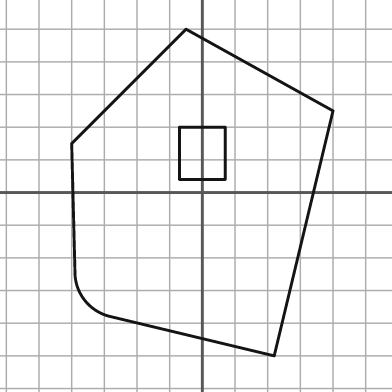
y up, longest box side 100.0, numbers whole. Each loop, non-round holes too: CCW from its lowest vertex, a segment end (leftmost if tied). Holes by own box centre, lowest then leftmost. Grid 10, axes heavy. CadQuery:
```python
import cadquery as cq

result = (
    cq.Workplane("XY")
    .moveTo(22.0, -50.0)
    .lineTo(40.0, 25.0)
    .lineTo(-5.0, 50.0)
    .lineTo(-40.0, 15.0)
    .lineTo(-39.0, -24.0)
    .threePointArc((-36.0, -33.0), (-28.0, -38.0))
    .close()
    .moveTo(-7.0, 4.0)
    .lineTo(7.0, 4.0)
    .lineTo(7.0, 20.0)
    .lineTo(-7.0, 20.0)
    .close()
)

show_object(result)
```